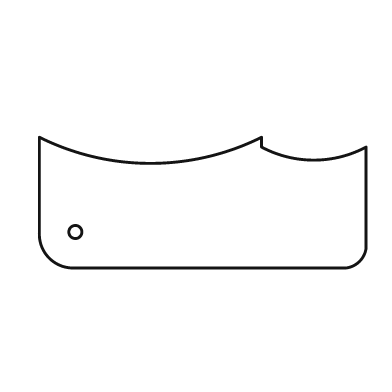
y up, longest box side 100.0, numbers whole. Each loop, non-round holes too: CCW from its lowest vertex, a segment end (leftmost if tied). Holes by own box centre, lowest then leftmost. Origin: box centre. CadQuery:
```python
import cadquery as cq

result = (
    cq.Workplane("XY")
    .moveTo(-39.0, -20.0)
    .lineTo(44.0, -20.0)
    .threePointArc((48.0, -18.0), (50.0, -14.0))
    .lineTo(50.0, 17.0)
    .threePointArc((34.0, 13.0), (18.0, 17.0))
    .lineTo(18.0, 20.0)
    .threePointArc((-16.0, 12.0), (-50.0, 20.0))
    .lineTo(-50.0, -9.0)
    .threePointArc((-47.0, -17.0), (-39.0, -20.0))
    .close()
    .moveTo(-39.0, -9.0)
    .circle(2.0)
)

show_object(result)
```